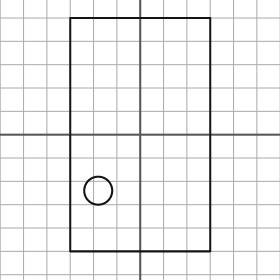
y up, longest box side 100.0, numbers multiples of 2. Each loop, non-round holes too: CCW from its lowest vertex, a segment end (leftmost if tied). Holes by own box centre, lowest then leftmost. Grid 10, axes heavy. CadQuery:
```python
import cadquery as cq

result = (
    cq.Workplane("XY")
    .moveTo(-30.0, -50.0)
    .lineTo(30.0, -50.0)
    .lineTo(30.0, 50.0)
    .lineTo(-30.0, 50.0)
    .close()
    .moveTo(-18.0, -24.0)
    .circle(6.0)
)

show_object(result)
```